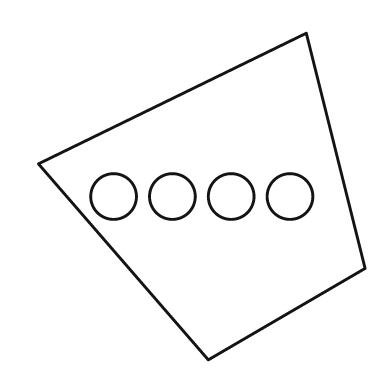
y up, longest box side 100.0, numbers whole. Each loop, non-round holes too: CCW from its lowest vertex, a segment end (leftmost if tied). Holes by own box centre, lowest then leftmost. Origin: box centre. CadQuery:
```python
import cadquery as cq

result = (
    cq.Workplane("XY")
    .moveTo(2.0, -50.0)
    .lineTo(50.0, -22.0)
    .lineTo(32.0, 50.0)
    .lineTo(-50.0, 10.0)
    .close()
    .moveTo(-27.0, 0.0)
    .circle(7.0)
    .moveTo(-9.0, 0.0)
    .circle(7.0)
    .moveTo(9.0, 0.0)
    .circle(7.0)
    .moveTo(27.0, 0.0)
    .circle(7.0)
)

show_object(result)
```